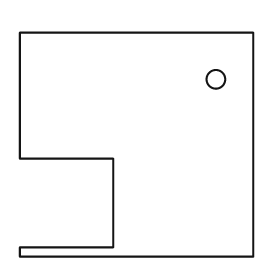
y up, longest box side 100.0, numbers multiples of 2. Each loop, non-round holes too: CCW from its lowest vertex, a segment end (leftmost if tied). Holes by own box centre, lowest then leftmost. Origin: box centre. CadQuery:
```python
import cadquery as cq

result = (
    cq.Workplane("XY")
    .moveTo(-50.0, -48.0)
    .lineTo(50.0, -48.0)
    .lineTo(50.0, 48.0)
    .lineTo(-50.0, 48.0)
    .lineTo(-50.0, -6.0)
    .lineTo(-10.0, -6.0)
    .lineTo(-10.0, -44.0)
    .lineTo(-50.0, -44.0)
    .close()
    .moveTo(34.0, 28.0)
    .circle(4.0)
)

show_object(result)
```